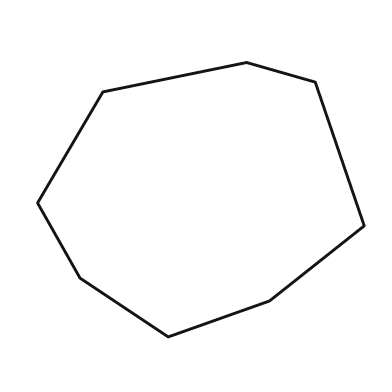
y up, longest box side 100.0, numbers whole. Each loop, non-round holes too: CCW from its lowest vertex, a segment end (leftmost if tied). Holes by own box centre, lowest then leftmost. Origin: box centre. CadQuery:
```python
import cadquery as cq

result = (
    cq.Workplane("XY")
    .moveTo(-10.0, -42.0)
    .lineTo(21.0, -31.0)
    .lineTo(50.0, -8.0)
    .lineTo(35.0, 36.0)
    .lineTo(14.0, 42.0)
    .lineTo(-30.0, 33.0)
    .lineTo(-50.0, -1.0)
    .lineTo(-37.0, -24.0)
    .close()
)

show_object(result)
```